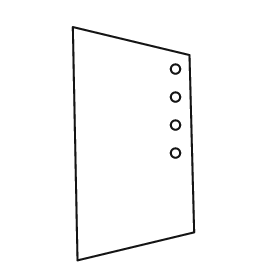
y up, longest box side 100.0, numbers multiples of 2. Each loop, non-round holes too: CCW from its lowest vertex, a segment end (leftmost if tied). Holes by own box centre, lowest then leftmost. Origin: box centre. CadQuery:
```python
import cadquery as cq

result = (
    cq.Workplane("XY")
    .moveTo(-24.0, -50.0)
    .lineTo(26.0, -38.0)
    .lineTo(24.0, 38.0)
    .lineTo(-26.0, 50.0)
    .close()
    .moveTo(18.0, -4.0)
    .circle(2.0)
    .moveTo(18.0, 8.0)
    .circle(2.0)
    .moveTo(18.0, 20.0)
    .circle(2.0)
    .moveTo(18.0, 32.0)
    .circle(2.0)
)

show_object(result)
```